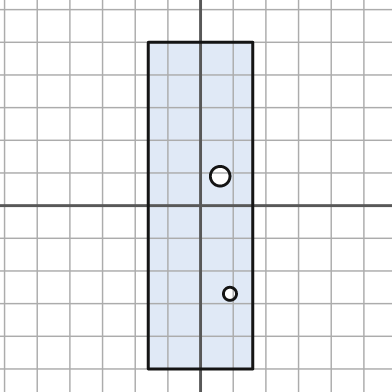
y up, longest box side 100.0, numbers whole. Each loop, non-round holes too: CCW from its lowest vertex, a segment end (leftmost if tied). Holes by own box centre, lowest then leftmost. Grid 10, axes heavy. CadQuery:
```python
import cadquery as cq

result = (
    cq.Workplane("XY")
    .moveTo(-16.0, -50.0)
    .lineTo(16.0, -50.0)
    .lineTo(16.0, 50.0)
    .lineTo(-16.0, 50.0)
    .close()
    .moveTo(9.0, -27.0)
    .circle(2.0)
    .moveTo(6.0, 9.0)
    .circle(3.0)
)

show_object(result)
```